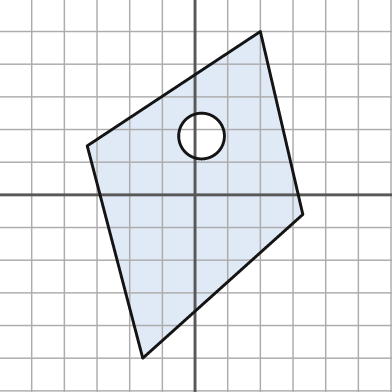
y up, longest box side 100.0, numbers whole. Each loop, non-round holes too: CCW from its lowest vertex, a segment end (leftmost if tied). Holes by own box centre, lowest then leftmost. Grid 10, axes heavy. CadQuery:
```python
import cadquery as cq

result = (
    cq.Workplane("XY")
    .moveTo(-16.0, -50.0)
    .lineTo(33.0, -6.0)
    .lineTo(20.0, 50.0)
    .lineTo(-33.0, 15.0)
    .close()
    .moveTo(2.0, 18.0)
    .circle(7.0)
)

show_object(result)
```